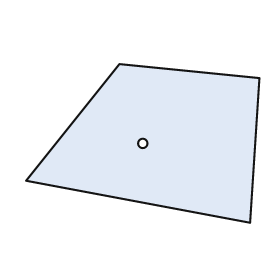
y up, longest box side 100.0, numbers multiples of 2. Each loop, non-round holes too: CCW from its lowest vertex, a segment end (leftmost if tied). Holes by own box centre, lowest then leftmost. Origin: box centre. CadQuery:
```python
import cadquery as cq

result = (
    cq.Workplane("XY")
    .moveTo(46.0, -34.0)
    .lineTo(50.0, 28.0)
    .lineTo(-10.0, 34.0)
    .lineTo(-50.0, -16.0)
    .close()
    .moveTo(0.0, 0.0)
    .circle(2.0)
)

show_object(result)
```